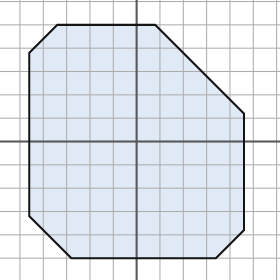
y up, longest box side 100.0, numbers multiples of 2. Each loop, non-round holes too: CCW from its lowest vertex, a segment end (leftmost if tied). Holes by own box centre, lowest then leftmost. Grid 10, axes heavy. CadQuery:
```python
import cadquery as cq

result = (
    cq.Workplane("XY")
    .moveTo(-28.0, -50.0)
    .lineTo(34.0, -50.0)
    .lineTo(46.0, -38.0)
    .lineTo(46.0, 12.0)
    .lineTo(8.0, 50.0)
    .lineTo(-34.0, 50.0)
    .lineTo(-46.0, 38.0)
    .lineTo(-46.0, -32.0)
    .close()
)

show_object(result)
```